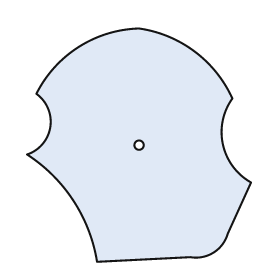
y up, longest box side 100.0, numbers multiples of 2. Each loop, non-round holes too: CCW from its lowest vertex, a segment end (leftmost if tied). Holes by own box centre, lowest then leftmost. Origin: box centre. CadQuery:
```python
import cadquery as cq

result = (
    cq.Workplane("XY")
    .moveTo(-18.0, -50.0)
    .lineTo(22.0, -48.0)
    .threePointArc((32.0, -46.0), (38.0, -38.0))
    .lineTo(48.0, -16.0)
    .threePointArc((36.0, 0.0), (40.0, 20.0))
    .threePointArc((24.0, 40.0), (0.0, 50.0))
    .threePointArc((-26.0, 42.0), (-44.0, 22.0))
    .threePointArc((-38.0, 8.0), (-48.0, -4.0))
    .threePointArc((-28.0, -24.0), (-18.0, -50.0))
    .close()
    .moveTo(0.0, 0.0)
    .circle(2.0)
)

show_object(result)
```